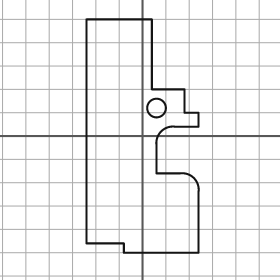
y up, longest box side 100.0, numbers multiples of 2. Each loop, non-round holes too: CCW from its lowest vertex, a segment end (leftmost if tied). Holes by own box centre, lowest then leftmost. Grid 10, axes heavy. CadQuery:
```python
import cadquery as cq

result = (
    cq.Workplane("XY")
    .moveTo(-8.0, -50.0)
    .lineTo(24.0, -50.0)
    .lineTo(24.0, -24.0)
    .threePointArc((22.0, -18.0), (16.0, -16.0))
    .lineTo(6.0, -16.0)
    .lineTo(6.0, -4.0)
    .threePointArc((8.0, 2.0), (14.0, 4.0))
    .lineTo(24.0, 4.0)
    .lineTo(24.0, 10.0)
    .lineTo(18.0, 10.0)
    .lineTo(18.0, 20.0)
    .lineTo(4.0, 20.0)
    .lineTo(4.0, 50.0)
    .lineTo(-24.0, 50.0)
    .lineTo(-24.0, -46.0)
    .lineTo(-8.0, -46.0)
    .close()
    .moveTo(6.0, 12.0)
    .circle(4.0)
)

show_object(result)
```